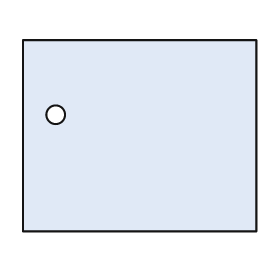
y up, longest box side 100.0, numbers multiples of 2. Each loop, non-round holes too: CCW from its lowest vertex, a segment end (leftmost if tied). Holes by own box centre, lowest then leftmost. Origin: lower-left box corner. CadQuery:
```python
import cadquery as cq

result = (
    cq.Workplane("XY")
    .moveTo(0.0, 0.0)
    .lineTo(100.0, 0.0)
    .lineTo(100.0, 82.0)
    .lineTo(0.0, 82.0)
    .close()
    .moveTo(14.0, 50.0)
    .circle(4.0)
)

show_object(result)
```